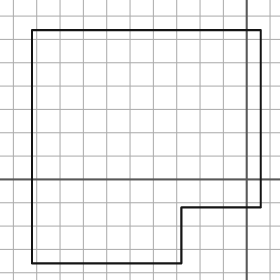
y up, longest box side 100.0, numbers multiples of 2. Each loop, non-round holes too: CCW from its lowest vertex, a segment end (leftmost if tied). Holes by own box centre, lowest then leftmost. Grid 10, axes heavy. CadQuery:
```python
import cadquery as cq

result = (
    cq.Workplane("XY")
    .moveTo(-92.0, -36.0)
    .lineTo(-28.0, -36.0)
    .lineTo(-28.0, -12.0)
    .lineTo(6.0, -12.0)
    .lineTo(6.0, 64.0)
    .lineTo(-92.0, 64.0)
    .close()
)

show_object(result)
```